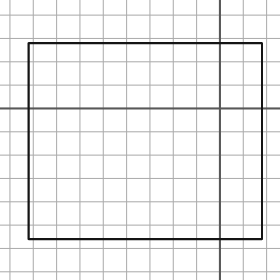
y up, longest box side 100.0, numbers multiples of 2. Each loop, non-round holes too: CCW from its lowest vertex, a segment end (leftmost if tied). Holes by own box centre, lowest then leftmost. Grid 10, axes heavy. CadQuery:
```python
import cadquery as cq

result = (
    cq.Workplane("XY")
    .moveTo(-82.0, -56.0)
    .lineTo(18.0, -56.0)
    .lineTo(18.0, 28.0)
    .lineTo(-82.0, 28.0)
    .close()
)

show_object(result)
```